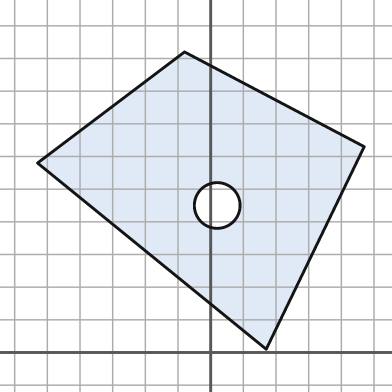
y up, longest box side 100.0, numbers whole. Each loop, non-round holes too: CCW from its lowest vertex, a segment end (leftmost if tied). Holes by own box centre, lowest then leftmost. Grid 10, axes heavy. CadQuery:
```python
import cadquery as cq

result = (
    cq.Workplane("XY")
    .moveTo(17.0, 1.0)
    .lineTo(47.0, 63.0)
    .lineTo(-8.0, 92.0)
    .lineTo(-53.0, 58.0)
    .close()
    .moveTo(2.0, 45.0)
    .circle(7.0)
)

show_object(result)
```